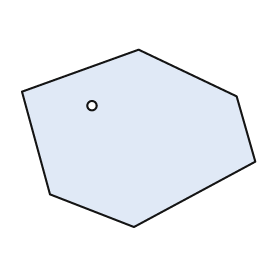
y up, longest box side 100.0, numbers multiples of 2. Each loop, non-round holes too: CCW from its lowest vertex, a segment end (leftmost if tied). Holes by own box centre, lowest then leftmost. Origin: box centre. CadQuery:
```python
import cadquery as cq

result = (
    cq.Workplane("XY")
    .moveTo(-2.0, -38.0)
    .lineTo(50.0, -10.0)
    .lineTo(42.0, 18.0)
    .lineTo(0.0, 38.0)
    .lineTo(-50.0, 20.0)
    .lineTo(-38.0, -24.0)
    .close()
    .moveTo(-20.0, 14.0)
    .circle(2.0)
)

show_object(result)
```